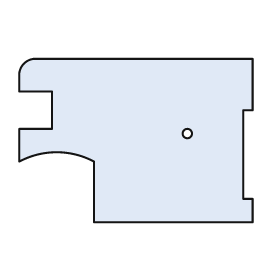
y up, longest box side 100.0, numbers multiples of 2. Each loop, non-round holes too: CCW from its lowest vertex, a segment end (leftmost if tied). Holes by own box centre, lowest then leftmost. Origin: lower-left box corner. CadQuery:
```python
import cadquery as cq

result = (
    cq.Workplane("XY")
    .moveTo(32.0, 0.0)
    .lineTo(100.0, 0.0)
    .lineTo(100.0, 10.0)
    .lineTo(96.0, 10.0)
    .lineTo(96.0, 48.0)
    .lineTo(100.0, 48.0)
    .lineTo(100.0, 70.0)
    .lineTo(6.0, 70.0)
    .threePointArc((2.0, 68.0), (0.0, 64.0))
    .lineTo(0.0, 56.0)
    .lineTo(14.0, 56.0)
    .lineTo(14.0, 40.0)
    .lineTo(0.0, 40.0)
    .lineTo(0.0, 26.0)
    .threePointArc((16.0, 30.0), (32.0, 26.0))
    .close()
    .moveTo(72.0, 38.0)
    .circle(2.0)
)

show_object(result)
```